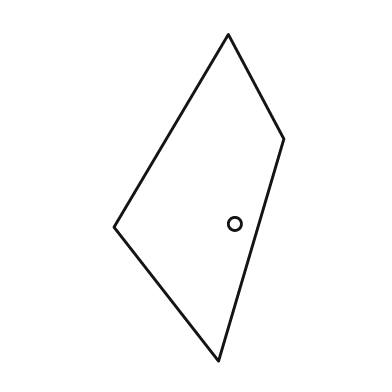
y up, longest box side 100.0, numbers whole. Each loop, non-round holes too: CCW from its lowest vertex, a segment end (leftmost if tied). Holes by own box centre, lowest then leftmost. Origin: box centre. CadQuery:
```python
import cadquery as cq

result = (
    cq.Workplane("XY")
    .moveTo(6.0, -50.0)
    .lineTo(26.0, 18.0)
    .lineTo(9.0, 50.0)
    .lineTo(-26.0, -9.0)
    .close()
    .moveTo(11.0, -8.0)
    .circle(2.0)
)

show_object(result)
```